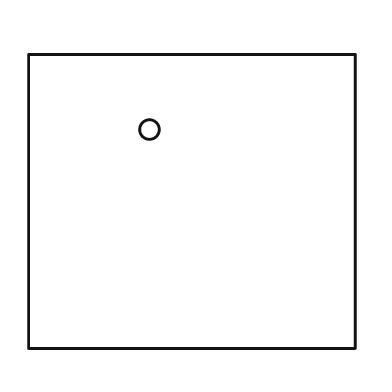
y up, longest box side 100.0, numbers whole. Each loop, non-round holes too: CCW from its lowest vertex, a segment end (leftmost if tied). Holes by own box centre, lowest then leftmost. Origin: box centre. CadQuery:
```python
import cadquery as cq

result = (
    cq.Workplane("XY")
    .moveTo(-50.0, -45.0)
    .lineTo(50.0, -45.0)
    .lineTo(50.0, 45.0)
    .lineTo(-50.0, 45.0)
    .close()
    .moveTo(-13.0, 22.0)
    .circle(3.0)
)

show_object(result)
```